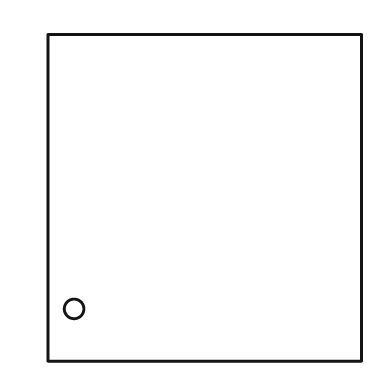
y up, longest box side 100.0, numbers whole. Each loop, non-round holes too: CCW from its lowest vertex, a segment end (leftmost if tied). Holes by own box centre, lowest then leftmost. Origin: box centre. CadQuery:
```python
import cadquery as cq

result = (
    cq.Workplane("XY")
    .moveTo(-48.0, -50.0)
    .lineTo(48.0, -50.0)
    .lineTo(48.0, 50.0)
    .lineTo(-48.0, 50.0)
    .close()
    .moveTo(-40.0, -34.0)
    .circle(3.0)
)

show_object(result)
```